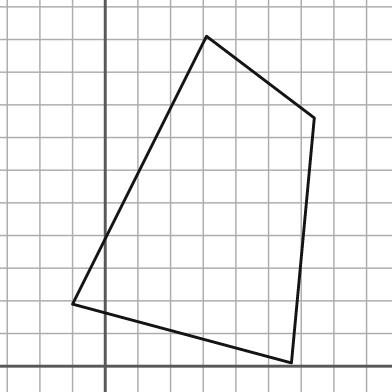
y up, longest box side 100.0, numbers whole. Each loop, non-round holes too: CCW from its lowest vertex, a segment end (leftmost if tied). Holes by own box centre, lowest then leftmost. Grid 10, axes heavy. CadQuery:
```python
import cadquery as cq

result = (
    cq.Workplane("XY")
    .moveTo(57.0, 1.0)
    .lineTo(64.0, 76.0)
    .lineTo(31.0, 101.0)
    .lineTo(-10.0, 19.0)
    .close()
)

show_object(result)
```